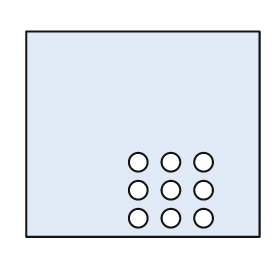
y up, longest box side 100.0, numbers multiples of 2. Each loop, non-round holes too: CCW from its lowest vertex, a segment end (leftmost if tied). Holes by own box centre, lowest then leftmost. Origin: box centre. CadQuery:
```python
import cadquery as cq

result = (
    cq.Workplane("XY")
    .moveTo(-50.0, -44.0)
    .lineTo(50.0, -44.0)
    .lineTo(50.0, 44.0)
    .lineTo(-50.0, 44.0)
    .close()
    .moveTo(-2.0, -36.0)
    .circle(4.0)
    .moveTo(12.0, -36.0)
    .circle(4.0)
    .moveTo(26.0, -36.0)
    .circle(4.0)
    .moveTo(-2.0, -24.0)
    .circle(4.0)
    .moveTo(12.0, -24.0)
    .circle(4.0)
    .moveTo(26.0, -24.0)
    .circle(4.0)
    .moveTo(-2.0, -12.0)
    .circle(4.0)
    .moveTo(12.0, -12.0)
    .circle(4.0)
    .moveTo(26.0, -12.0)
    .circle(4.0)
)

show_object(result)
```